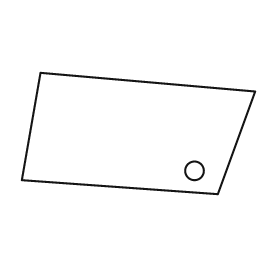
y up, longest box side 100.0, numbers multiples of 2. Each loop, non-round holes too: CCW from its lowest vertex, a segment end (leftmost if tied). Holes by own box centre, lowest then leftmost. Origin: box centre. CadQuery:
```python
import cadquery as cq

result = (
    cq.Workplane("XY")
    .moveTo(34.0, -26.0)
    .lineTo(50.0, 18.0)
    .lineTo(-42.0, 26.0)
    .lineTo(-50.0, -20.0)
    .close()
    .moveTo(24.0, -16.0)
    .circle(4.0)
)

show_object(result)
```